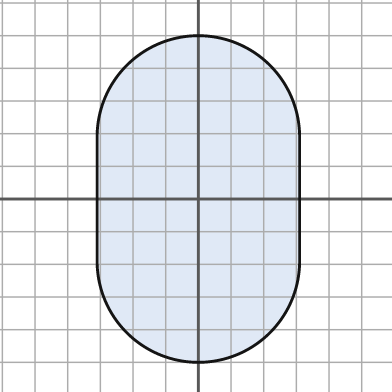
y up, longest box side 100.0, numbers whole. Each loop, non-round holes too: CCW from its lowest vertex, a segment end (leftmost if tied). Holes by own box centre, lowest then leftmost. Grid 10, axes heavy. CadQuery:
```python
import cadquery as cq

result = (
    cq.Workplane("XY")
    .moveTo(-31.0, -19.0)
    .threePointArc((0.0, -50.0), (31.0, -19.0))
    .lineTo(31.0, 19.0)
    .threePointArc((0.0, 50.0), (-31.0, 19.0))
    .close()
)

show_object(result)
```